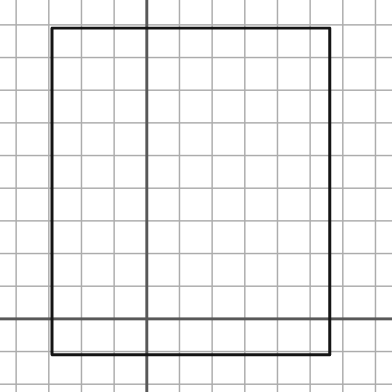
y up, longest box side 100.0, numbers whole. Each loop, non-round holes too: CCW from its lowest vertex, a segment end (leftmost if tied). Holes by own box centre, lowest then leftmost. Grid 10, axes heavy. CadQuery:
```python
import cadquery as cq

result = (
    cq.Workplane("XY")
    .moveTo(-29.0, -11.0)
    .lineTo(56.0, -11.0)
    .lineTo(56.0, 89.0)
    .lineTo(-29.0, 89.0)
    .close()
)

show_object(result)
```